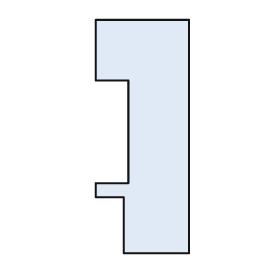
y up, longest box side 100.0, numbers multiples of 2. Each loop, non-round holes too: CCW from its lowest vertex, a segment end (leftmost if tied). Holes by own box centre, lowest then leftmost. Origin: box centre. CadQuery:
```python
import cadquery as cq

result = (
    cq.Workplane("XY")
    .moveTo(-8.0, -50.0)
    .lineTo(20.0, -50.0)
    .lineTo(20.0, 50.0)
    .lineTo(-20.0, 50.0)
    .lineTo(-20.0, 24.0)
    .lineTo(-6.0, 24.0)
    .lineTo(-6.0, -20.0)
    .lineTo(-20.0, -20.0)
    .lineTo(-20.0, -26.0)
    .lineTo(-8.0, -26.0)
    .close()
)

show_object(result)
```